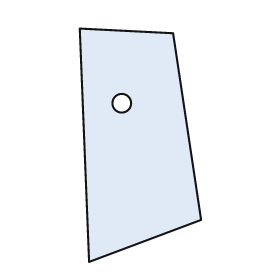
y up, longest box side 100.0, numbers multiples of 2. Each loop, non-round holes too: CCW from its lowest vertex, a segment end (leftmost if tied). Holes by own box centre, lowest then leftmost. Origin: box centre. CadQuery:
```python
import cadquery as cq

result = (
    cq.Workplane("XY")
    .moveTo(-22.0, -50.0)
    .lineTo(26.0, -32.0)
    .lineTo(14.0, 48.0)
    .lineTo(-26.0, 50.0)
    .close()
    .moveTo(-8.0, 18.0)
    .circle(4.0)
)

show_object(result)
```